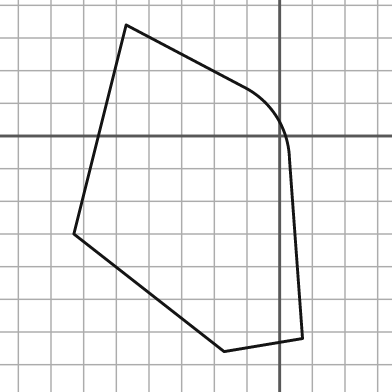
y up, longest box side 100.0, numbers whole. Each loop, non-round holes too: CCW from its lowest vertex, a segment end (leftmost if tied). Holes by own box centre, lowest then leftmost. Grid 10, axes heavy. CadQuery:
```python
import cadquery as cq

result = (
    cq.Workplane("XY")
    .moveTo(-17.0, -66.0)
    .lineTo(7.0, -62.0)
    .lineTo(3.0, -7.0)
    .threePointArc((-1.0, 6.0), (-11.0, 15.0))
    .lineTo(-47.0, 34.0)
    .lineTo(-63.0, -30.0)
    .close()
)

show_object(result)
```